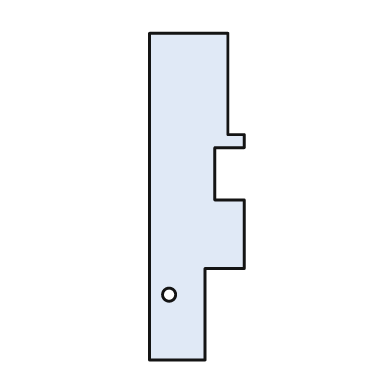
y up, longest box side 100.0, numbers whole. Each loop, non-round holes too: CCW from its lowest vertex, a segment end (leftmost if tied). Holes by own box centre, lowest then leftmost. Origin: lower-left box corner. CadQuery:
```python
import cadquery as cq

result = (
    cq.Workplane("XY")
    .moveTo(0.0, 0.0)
    .lineTo(17.0, 0.0)
    .lineTo(17.0, 28.0)
    .lineTo(29.0, 28.0)
    .lineTo(29.0, 49.0)
    .lineTo(20.0, 49.0)
    .lineTo(20.0, 65.0)
    .lineTo(29.0, 65.0)
    .lineTo(29.0, 69.0)
    .lineTo(24.0, 69.0)
    .lineTo(24.0, 100.0)
    .lineTo(0.0, 100.0)
    .close()
    .moveTo(6.0, 20.0)
    .circle(2.0)
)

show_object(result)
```